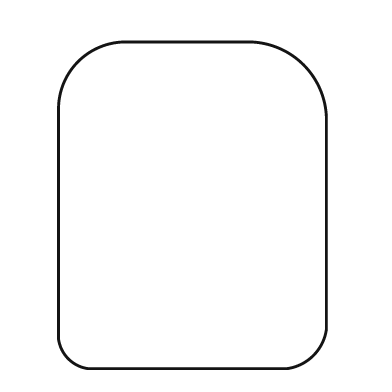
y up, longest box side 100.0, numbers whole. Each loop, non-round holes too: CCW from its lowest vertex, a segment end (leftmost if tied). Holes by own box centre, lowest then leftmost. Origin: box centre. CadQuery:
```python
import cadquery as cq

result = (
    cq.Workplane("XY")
    .moveTo(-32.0, -50.0)
    .lineTo(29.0, -50.0)
    .threePointArc((37.0, -46.0), (41.0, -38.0))
    .lineTo(41.0, 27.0)
    .threePointArc((34.0, 43.0), (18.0, 50.0))
    .lineTo(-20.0, 50.0)
    .threePointArc((-35.0, 44.0), (-41.0, 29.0))
    .lineTo(-41.0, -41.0)
    .threePointArc((-38.0, -47.0), (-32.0, -50.0))
    .close()
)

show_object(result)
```